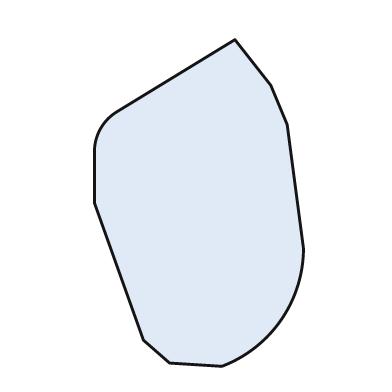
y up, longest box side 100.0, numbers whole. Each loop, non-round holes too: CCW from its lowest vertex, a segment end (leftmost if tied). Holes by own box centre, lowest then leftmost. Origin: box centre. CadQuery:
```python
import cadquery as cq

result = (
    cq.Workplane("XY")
    .moveTo(7.0, -50.0)
    .threePointArc((25.0, -36.0), (32.0, -14.0))
    .lineTo(27.0, 24.0)
    .lineTo(22.0, 36.0)
    .lineTo(11.0, 50.0)
    .lineTo(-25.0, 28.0)
    .threePointArc((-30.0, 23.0), (-32.0, 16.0))
    .lineTo(-32.0, 0.0)
    .lineTo(-17.0, -42.0)
    .lineTo(-9.0, -49.0)
    .close()
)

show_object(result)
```